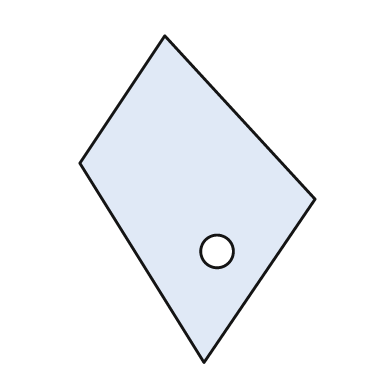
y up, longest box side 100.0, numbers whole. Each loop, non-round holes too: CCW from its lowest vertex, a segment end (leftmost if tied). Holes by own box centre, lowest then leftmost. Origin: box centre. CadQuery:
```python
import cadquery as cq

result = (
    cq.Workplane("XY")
    .moveTo(2.0, -50.0)
    .lineTo(36.0, 0.0)
    .lineTo(-10.0, 50.0)
    .lineTo(-36.0, 11.0)
    .close()
    .moveTo(6.0, -16.0)
    .circle(5.0)
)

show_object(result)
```